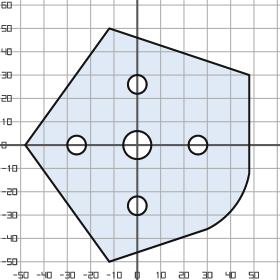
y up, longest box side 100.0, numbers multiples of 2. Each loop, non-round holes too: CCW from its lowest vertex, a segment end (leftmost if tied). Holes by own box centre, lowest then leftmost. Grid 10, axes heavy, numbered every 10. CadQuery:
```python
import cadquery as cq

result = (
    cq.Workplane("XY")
    .moveTo(-12.0, -50.0)
    .lineTo(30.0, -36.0)
    .threePointArc((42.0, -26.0), (48.0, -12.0))
    .lineTo(48.0, 30.0)
    .lineTo(-12.0, 50.0)
    .lineTo(-48.0, 0.0)
    .close()
    .moveTo(0.0, -26.0)
    .circle(4.0)
    .moveTo(-26.0, 0.0)
    .circle(4.0)
    .moveTo(0.0, 0.0)
    .circle(6.0)
    .moveTo(26.0, 0.0)
    .circle(4.0)
    .moveTo(0.0, 26.0)
    .circle(4.0)
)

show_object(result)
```